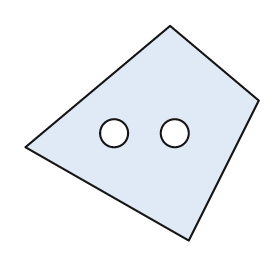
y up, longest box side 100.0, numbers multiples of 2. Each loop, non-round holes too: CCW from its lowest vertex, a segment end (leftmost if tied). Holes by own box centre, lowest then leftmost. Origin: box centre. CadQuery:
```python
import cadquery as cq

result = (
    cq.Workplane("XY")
    .moveTo(20.0, -46.0)
    .lineTo(50.0, 14.0)
    .lineTo(12.0, 46.0)
    .lineTo(-50.0, -6.0)
    .close()
    .moveTo(-12.0, 0.0)
    .circle(6.0)
    .moveTo(14.0, 0.0)
    .circle(6.0)
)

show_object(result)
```